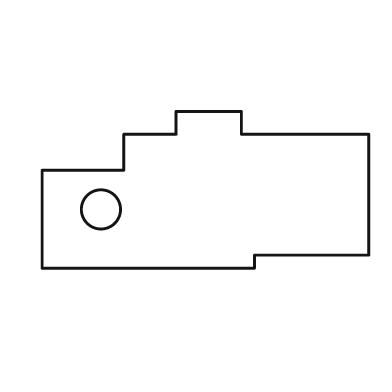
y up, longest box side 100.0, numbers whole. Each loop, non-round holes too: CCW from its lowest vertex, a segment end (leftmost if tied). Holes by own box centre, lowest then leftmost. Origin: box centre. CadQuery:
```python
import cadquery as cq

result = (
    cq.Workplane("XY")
    .moveTo(-50.0, -24.0)
    .lineTo(15.0, -24.0)
    .lineTo(15.0, -20.0)
    .lineTo(50.0, -20.0)
    .lineTo(50.0, 17.0)
    .lineTo(11.0, 17.0)
    .lineTo(11.0, 24.0)
    .lineTo(-9.0, 24.0)
    .lineTo(-9.0, 17.0)
    .lineTo(-25.0, 17.0)
    .lineTo(-25.0, 6.0)
    .lineTo(-50.0, 6.0)
    .close()
    .moveTo(-32.0, -6.0)
    .circle(6.0)
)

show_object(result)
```